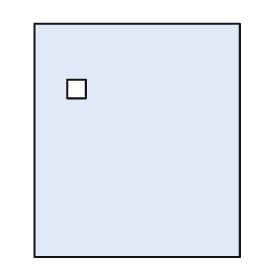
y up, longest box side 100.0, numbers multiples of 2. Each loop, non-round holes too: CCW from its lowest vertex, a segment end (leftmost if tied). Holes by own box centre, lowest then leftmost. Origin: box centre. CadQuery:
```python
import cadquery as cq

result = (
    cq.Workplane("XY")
    .moveTo(-44.0, -50.0)
    .lineTo(44.0, -50.0)
    .lineTo(44.0, 50.0)
    .lineTo(-44.0, 50.0)
    .close()
    .moveTo(-30.0, 18.0)
    .lineTo(-22.0, 18.0)
    .lineTo(-22.0, 26.0)
    .lineTo(-30.0, 26.0)
    .close()
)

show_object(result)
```